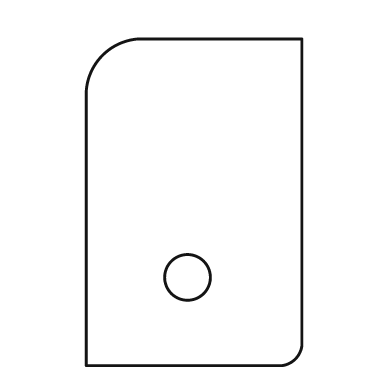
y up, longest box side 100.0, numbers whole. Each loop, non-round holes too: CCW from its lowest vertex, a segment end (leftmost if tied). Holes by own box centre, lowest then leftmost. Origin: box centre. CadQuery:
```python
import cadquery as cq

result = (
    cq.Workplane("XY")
    .moveTo(-33.0, -50.0)
    .lineTo(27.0, -50.0)
    .threePointArc((31.0, -48.0), (33.0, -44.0))
    .lineTo(33.0, 50.0)
    .lineTo(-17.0, 50.0)
    .threePointArc((-28.0, 45.0), (-33.0, 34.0))
    .close()
    .moveTo(-2.0, -23.0)
    .circle(7.0)
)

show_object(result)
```